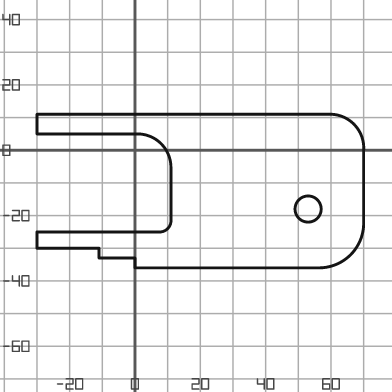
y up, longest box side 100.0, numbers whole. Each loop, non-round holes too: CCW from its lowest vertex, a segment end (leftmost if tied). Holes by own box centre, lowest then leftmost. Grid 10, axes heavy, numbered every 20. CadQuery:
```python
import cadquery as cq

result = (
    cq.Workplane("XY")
    .moveTo(0.0, -36.0)
    .lineTo(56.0, -36.0)
    .threePointArc((66.0, -32.0), (70.0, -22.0))
    .lineTo(70.0, 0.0)
    .threePointArc((67.0, 8.0), (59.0, 11.0))
    .lineTo(-30.0, 11.0)
    .lineTo(-30.0, 5.0)
    .lineTo(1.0, 5.0)
    .threePointArc((8.0, 2.0), (11.0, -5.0))
    .lineTo(11.0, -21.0)
    .threePointArc((10.0, -24.0), (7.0, -25.0))
    .lineTo(-30.0, -25.0)
    .lineTo(-30.0, -30.0)
    .lineTo(-11.0, -30.0)
    .lineTo(-11.0, -33.0)
    .lineTo(0.0, -33.0)
    .close()
    .moveTo(53.0, -18.0)
    .circle(4.0)
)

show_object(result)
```